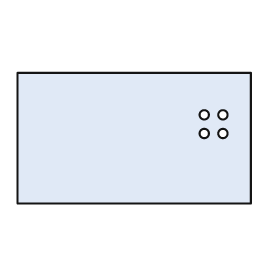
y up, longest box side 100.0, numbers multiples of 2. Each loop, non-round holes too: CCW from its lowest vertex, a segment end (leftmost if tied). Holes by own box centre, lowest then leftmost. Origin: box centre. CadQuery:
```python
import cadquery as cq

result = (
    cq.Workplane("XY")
    .moveTo(-50.0, -28.0)
    .lineTo(50.0, -28.0)
    .lineTo(50.0, 28.0)
    .lineTo(-50.0, 28.0)
    .close()
    .moveTo(30.0, 2.0)
    .circle(2.0)
    .moveTo(38.0, 2.0)
    .circle(2.0)
    .moveTo(30.0, 10.0)
    .circle(2.0)
    .moveTo(38.0, 10.0)
    .circle(2.0)
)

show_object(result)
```